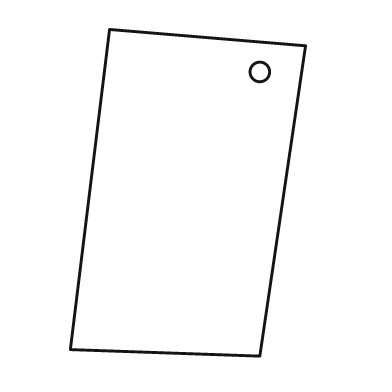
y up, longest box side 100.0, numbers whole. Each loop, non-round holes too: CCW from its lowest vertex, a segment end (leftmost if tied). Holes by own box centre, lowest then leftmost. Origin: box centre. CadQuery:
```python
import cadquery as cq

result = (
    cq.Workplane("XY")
    .moveTo(22.0, -50.0)
    .lineTo(36.0, 45.0)
    .lineTo(-24.0, 50.0)
    .lineTo(-36.0, -48.0)
    .close()
    .moveTo(22.0, 37.0)
    .circle(3.0)
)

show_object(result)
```